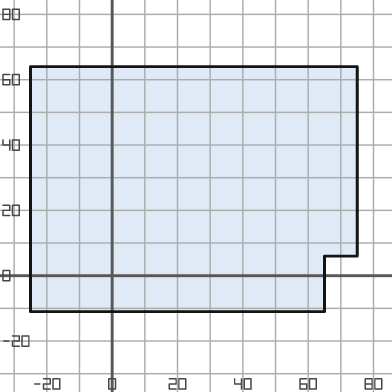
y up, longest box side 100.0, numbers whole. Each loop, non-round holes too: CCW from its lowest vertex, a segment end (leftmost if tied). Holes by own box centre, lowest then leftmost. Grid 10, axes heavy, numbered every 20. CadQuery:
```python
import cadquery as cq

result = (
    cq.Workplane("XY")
    .moveTo(-25.0, -11.0)
    .lineTo(65.0, -11.0)
    .lineTo(65.0, 6.0)
    .lineTo(75.0, 6.0)
    .lineTo(75.0, 64.0)
    .lineTo(-25.0, 64.0)
    .close()
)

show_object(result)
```